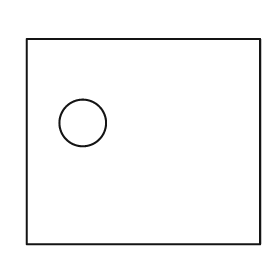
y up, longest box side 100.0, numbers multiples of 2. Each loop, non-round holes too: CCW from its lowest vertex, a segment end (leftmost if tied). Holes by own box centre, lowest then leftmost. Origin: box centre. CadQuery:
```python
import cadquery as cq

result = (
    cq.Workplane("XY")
    .moveTo(-50.0, -44.0)
    .lineTo(50.0, -44.0)
    .lineTo(50.0, 44.0)
    .lineTo(-50.0, 44.0)
    .close()
    .moveTo(-26.0, 8.0)
    .circle(10.0)
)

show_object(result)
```